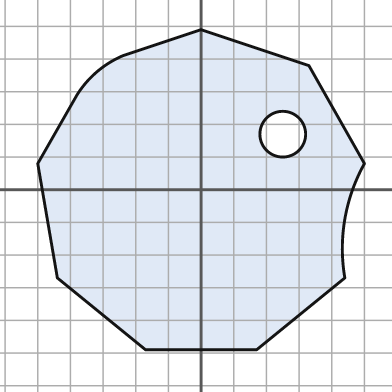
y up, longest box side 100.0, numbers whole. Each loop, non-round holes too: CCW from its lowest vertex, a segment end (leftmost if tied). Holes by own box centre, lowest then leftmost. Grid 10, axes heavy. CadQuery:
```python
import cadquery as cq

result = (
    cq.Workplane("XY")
    .moveTo(-17.0, -49.0)
    .lineTo(17.0, -49.0)
    .lineTo(44.0, -27.0)
    .threePointArc((44.0, -9.0), (50.0, 8.0))
    .lineTo(33.0, 38.0)
    .lineTo(0.0, 49.0)
    .lineTo(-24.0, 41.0)
    .threePointArc((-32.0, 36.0), (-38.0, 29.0))
    .lineTo(-50.0, 8.0)
    .lineTo(-44.0, -27.0)
    .close()
    .moveTo(25.0, 17.0)
    .circle(7.0)
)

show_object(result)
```